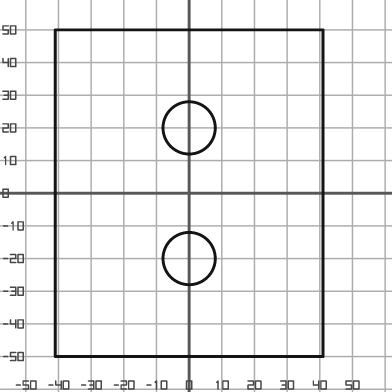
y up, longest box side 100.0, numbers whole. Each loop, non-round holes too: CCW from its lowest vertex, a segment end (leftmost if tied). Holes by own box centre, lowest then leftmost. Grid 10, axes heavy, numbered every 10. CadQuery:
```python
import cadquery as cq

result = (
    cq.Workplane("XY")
    .moveTo(-41.0, -50.0)
    .lineTo(41.0, -50.0)
    .lineTo(41.0, 50.0)
    .lineTo(-41.0, 50.0)
    .close()
    .moveTo(0.0, -20.0)
    .circle(8.0)
    .moveTo(0.0, 20.0)
    .circle(8.0)
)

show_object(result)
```